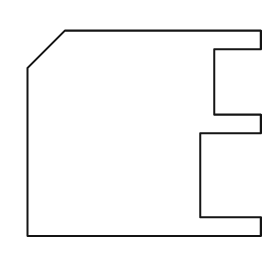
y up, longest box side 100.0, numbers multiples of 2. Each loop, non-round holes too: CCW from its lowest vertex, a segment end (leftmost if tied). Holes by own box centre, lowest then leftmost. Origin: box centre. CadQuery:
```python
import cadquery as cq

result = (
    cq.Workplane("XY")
    .moveTo(-50.0, -44.0)
    .lineTo(50.0, -44.0)
    .lineTo(50.0, -36.0)
    .lineTo(24.0, -36.0)
    .lineTo(24.0, 0.0)
    .lineTo(50.0, 0.0)
    .lineTo(50.0, 8.0)
    .lineTo(30.0, 8.0)
    .lineTo(30.0, 36.0)
    .lineTo(50.0, 36.0)
    .lineTo(50.0, 44.0)
    .lineTo(-34.0, 44.0)
    .lineTo(-50.0, 28.0)
    .close()
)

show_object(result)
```